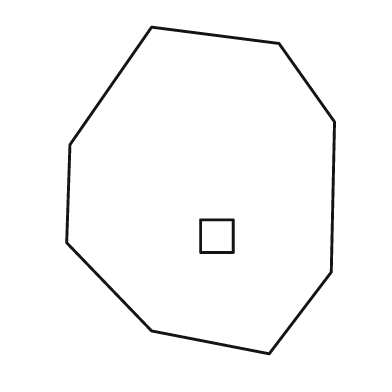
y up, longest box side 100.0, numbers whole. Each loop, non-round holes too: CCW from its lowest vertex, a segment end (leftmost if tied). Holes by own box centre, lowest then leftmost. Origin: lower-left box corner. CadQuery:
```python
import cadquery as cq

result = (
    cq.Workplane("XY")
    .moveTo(62.0, 0.0)
    .lineTo(81.0, 25.0)
    .lineTo(82.0, 71.0)
    .lineTo(65.0, 95.0)
    .lineTo(26.0, 100.0)
    .lineTo(1.0, 64.0)
    .lineTo(0.0, 34.0)
    .lineTo(26.0, 7.0)
    .close()
    .moveTo(41.0, 31.0)
    .lineTo(51.0, 31.0)
    .lineTo(51.0, 41.0)
    .lineTo(41.0, 41.0)
    .close()
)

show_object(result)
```